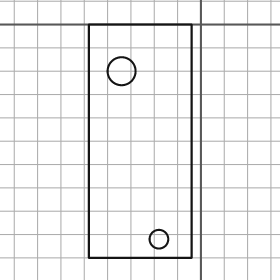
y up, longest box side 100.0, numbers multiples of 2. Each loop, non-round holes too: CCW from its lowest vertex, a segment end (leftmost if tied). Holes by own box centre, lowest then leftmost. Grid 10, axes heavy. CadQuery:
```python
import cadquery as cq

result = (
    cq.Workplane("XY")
    .moveTo(-48.0, -100.0)
    .lineTo(-4.0, -100.0)
    .lineTo(-4.0, 0.0)
    .lineTo(-48.0, 0.0)
    .close()
    .moveTo(-18.0, -92.0)
    .circle(4.0)
    .moveTo(-34.0, -20.0)
    .circle(6.0)
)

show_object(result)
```